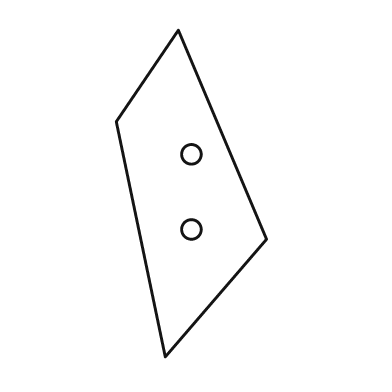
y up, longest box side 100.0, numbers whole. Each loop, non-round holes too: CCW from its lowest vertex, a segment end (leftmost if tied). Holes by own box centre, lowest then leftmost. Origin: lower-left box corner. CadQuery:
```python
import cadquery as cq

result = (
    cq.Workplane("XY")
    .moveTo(15.0, 0.0)
    .lineTo(46.0, 36.0)
    .lineTo(19.0, 100.0)
    .lineTo(0.0, 72.0)
    .close()
    .moveTo(23.0, 39.0)
    .circle(3.0)
    .moveTo(23.0, 62.0)
    .circle(3.0)
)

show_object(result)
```